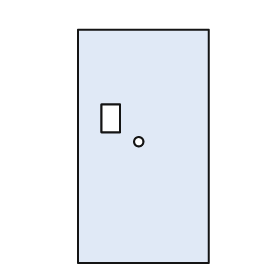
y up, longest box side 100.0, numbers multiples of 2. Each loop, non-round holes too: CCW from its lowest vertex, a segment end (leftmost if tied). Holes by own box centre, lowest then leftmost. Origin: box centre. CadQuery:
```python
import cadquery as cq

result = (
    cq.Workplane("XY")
    .moveTo(-28.0, -50.0)
    .lineTo(28.0, -50.0)
    .lineTo(28.0, 50.0)
    .lineTo(-28.0, 50.0)
    .close()
    .moveTo(-2.0, 2.0)
    .circle(2.0)
    .moveTo(-18.0, 6.0)
    .lineTo(-10.0, 6.0)
    .lineTo(-10.0, 18.0)
    .lineTo(-18.0, 18.0)
    .close()
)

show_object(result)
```